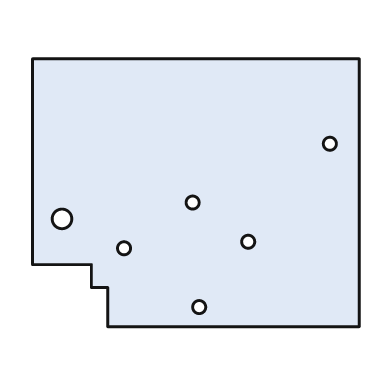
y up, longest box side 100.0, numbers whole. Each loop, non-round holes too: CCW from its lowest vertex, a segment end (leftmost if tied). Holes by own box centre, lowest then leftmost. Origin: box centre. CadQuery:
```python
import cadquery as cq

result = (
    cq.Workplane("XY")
    .moveTo(-27.0, -41.0)
    .lineTo(50.0, -41.0)
    .lineTo(50.0, 41.0)
    .lineTo(-50.0, 41.0)
    .lineTo(-50.0, -22.0)
    .lineTo(-32.0, -22.0)
    .lineTo(-32.0, -29.0)
    .lineTo(-27.0, -29.0)
    .close()
    .moveTo(1.0, -35.0)
    .circle(2.0)
    .moveTo(-22.0, -17.0)
    .circle(2.0)
    .moveTo(16.0, -15.0)
    .circle(2.0)
    .moveTo(-41.0, -8.0)
    .circle(3.0)
    .moveTo(-1.0, -3.0)
    .circle(2.0)
    .moveTo(41.0, 15.0)
    .circle(2.0)
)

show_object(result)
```